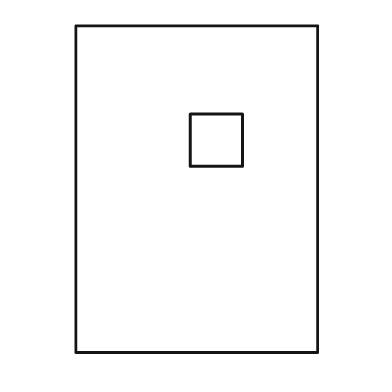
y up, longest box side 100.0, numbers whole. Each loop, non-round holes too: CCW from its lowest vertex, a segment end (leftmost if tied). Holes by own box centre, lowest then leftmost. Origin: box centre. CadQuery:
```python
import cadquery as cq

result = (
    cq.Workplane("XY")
    .moveTo(-37.0, -50.0)
    .lineTo(37.0, -50.0)
    .lineTo(37.0, 50.0)
    .lineTo(-37.0, 50.0)
    .close()
    .moveTo(-2.0, 7.0)
    .lineTo(14.0, 7.0)
    .lineTo(14.0, 23.0)
    .lineTo(-2.0, 23.0)
    .close()
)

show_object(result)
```